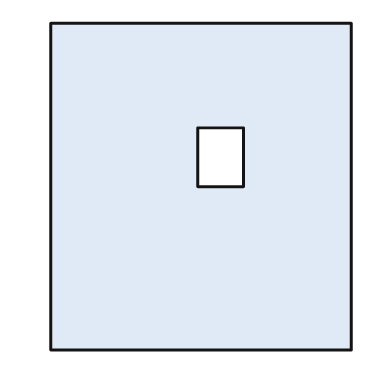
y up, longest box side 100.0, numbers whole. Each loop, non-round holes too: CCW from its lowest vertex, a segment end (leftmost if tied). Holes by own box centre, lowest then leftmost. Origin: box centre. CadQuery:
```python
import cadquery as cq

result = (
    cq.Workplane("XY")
    .moveTo(-46.0, -50.0)
    .lineTo(46.0, -50.0)
    .lineTo(46.0, 50.0)
    .lineTo(-46.0, 50.0)
    .close()
    .moveTo(-1.0, 0.0)
    .lineTo(13.0, 0.0)
    .lineTo(13.0, 18.0)
    .lineTo(-1.0, 18.0)
    .close()
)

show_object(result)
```